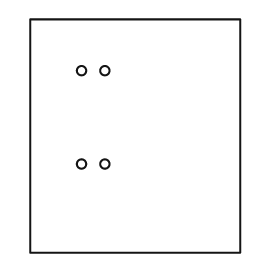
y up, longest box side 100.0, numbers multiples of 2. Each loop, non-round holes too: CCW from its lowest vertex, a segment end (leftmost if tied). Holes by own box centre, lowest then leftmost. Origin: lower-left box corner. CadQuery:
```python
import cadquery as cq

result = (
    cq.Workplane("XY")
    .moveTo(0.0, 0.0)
    .lineTo(90.0, 0.0)
    .lineTo(90.0, 100.0)
    .lineTo(0.0, 100.0)
    .close()
    .moveTo(22.0, 38.0)
    .circle(2.0)
    .moveTo(32.0, 38.0)
    .circle(2.0)
    .moveTo(22.0, 78.0)
    .circle(2.0)
    .moveTo(32.0, 78.0)
    .circle(2.0)
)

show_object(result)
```